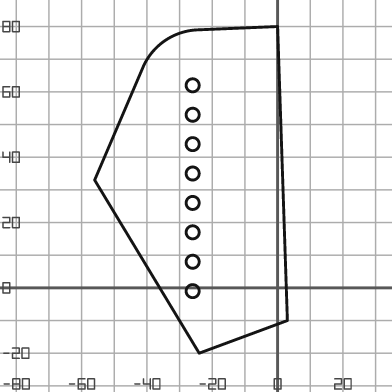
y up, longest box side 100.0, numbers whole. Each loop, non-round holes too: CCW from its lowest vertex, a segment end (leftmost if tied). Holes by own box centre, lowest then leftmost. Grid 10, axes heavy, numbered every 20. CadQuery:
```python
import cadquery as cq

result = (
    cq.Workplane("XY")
    .moveTo(-24.0, -20.0)
    .lineTo(3.0, -10.0)
    .lineTo(0.0, 80.0)
    .lineTo(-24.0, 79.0)
    .threePointArc((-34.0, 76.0), (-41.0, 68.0))
    .lineTo(-56.0, 33.0)
    .close()
    .moveTo(-26.0, -1.0)
    .circle(2.0)
    .moveTo(-26.0, 8.0)
    .circle(2.0)
    .moveTo(-26.0, 17.0)
    .circle(2.0)
    .moveTo(-26.0, 26.0)
    .circle(2.0)
    .moveTo(-26.0, 35.0)
    .circle(2.0)
    .moveTo(-26.0, 44.0)
    .circle(2.0)
    .moveTo(-26.0, 53.0)
    .circle(2.0)
    .moveTo(-26.0, 62.0)
    .circle(2.0)
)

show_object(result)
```